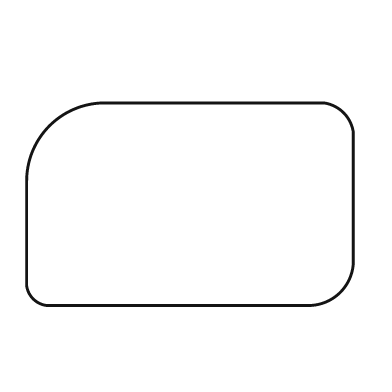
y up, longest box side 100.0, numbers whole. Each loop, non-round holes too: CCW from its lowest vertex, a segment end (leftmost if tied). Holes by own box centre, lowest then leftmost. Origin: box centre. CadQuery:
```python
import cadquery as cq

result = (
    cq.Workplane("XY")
    .moveTo(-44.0, -31.0)
    .lineTo(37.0, -31.0)
    .threePointArc((46.0, -27.0), (50.0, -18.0))
    .lineTo(50.0, 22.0)
    .threePointArc((47.0, 28.0), (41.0, 31.0))
    .lineTo(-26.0, 31.0)
    .threePointArc((-43.0, 24.0), (-50.0, 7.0))
    .lineTo(-50.0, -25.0)
    .threePointArc((-48.0, -29.0), (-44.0, -31.0))
    .close()
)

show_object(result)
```